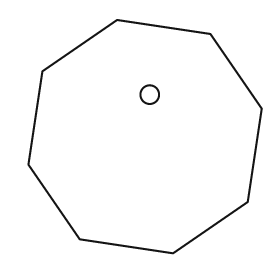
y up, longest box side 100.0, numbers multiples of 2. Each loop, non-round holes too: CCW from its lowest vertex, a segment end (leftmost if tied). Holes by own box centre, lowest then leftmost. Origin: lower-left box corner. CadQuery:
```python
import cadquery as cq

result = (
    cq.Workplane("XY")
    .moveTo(62.0, 0.0)
    .lineTo(94.0, 22.0)
    .lineTo(100.0, 62.0)
    .lineTo(78.0, 94.0)
    .lineTo(38.0, 100.0)
    .lineTo(6.0, 78.0)
    .lineTo(0.0, 38.0)
    .lineTo(22.0, 6.0)
    .close()
    .moveTo(52.0, 68.0)
    .circle(4.0)
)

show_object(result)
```